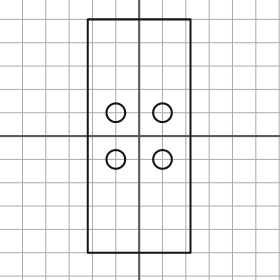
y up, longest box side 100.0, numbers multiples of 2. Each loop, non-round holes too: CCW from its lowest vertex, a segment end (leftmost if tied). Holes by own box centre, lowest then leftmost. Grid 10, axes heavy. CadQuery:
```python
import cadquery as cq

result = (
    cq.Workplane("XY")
    .moveTo(-22.0, -50.0)
    .lineTo(22.0, -50.0)
    .lineTo(22.0, 50.0)
    .lineTo(-22.0, 50.0)
    .close()
    .moveTo(-10.0, -10.0)
    .circle(4.0)
    .moveTo(10.0, -10.0)
    .circle(4.0)
    .moveTo(-10.0, 10.0)
    .circle(4.0)
    .moveTo(10.0, 10.0)
    .circle(4.0)
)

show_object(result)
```